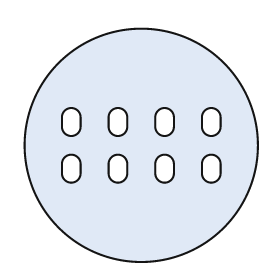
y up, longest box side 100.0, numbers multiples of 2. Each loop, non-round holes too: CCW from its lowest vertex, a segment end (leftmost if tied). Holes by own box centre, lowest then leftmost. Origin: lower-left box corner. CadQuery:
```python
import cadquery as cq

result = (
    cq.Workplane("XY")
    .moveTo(50.0, 50.0)
    .circle(50.0)
    .moveTo(16.0, 38.0)
    .threePointArc((20.0, 34.0), (24.0, 38.0))
    .lineTo(24.0, 42.0)
    .threePointArc((20.0, 46.0), (16.0, 42.0))
    .close()
    .moveTo(36.0, 38.0)
    .threePointArc((40.0, 34.0), (44.0, 38.0))
    .lineTo(44.0, 42.0)
    .threePointArc((40.0, 46.0), (36.0, 42.0))
    .close()
    .moveTo(56.0, 38.0)
    .threePointArc((60.0, 34.0), (64.0, 38.0))
    .lineTo(64.0, 42.0)
    .threePointArc((60.0, 46.0), (56.0, 42.0))
    .close()
    .moveTo(76.0, 38.0)
    .threePointArc((80.0, 34.0), (84.0, 38.0))
    .lineTo(84.0, 42.0)
    .threePointArc((80.0, 46.0), (76.0, 42.0))
    .close()
    .moveTo(16.0, 58.0)
    .threePointArc((20.0, 54.0), (24.0, 58.0))
    .lineTo(24.0, 62.0)
    .threePointArc((20.0, 66.0), (16.0, 62.0))
    .close()
    .moveTo(36.0, 58.0)
    .threePointArc((40.0, 54.0), (44.0, 58.0))
    .lineTo(44.0, 62.0)
    .threePointArc((40.0, 66.0), (36.0, 62.0))
    .close()
    .moveTo(56.0, 58.0)
    .threePointArc((60.0, 54.0), (64.0, 58.0))
    .lineTo(64.0, 62.0)
    .threePointArc((60.0, 66.0), (56.0, 62.0))
    .close()
    .moveTo(76.0, 58.0)
    .threePointArc((80.0, 54.0), (84.0, 58.0))
    .lineTo(84.0, 62.0)
    .threePointArc((80.0, 66.0), (76.0, 62.0))
    .close()
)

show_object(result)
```